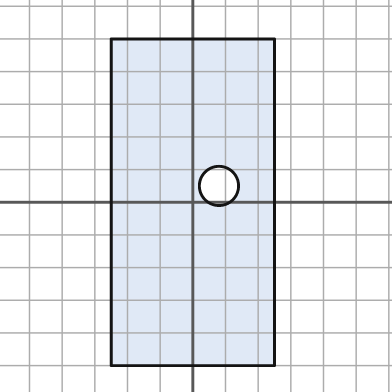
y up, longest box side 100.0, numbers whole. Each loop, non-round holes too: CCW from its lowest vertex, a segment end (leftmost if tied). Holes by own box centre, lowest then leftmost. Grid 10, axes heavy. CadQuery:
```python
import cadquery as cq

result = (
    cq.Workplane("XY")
    .moveTo(-25.0, -50.0)
    .lineTo(25.0, -50.0)
    .lineTo(25.0, 50.0)
    .lineTo(-25.0, 50.0)
    .close()
    .moveTo(8.0, 5.0)
    .circle(6.0)
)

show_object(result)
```